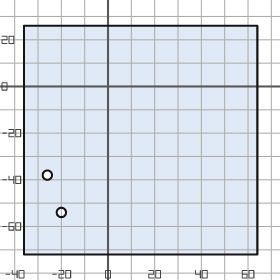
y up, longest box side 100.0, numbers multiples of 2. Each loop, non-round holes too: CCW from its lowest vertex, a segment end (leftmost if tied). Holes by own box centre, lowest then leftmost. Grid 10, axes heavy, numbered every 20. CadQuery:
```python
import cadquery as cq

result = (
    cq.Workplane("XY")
    .moveTo(-36.0, -72.0)
    .lineTo(64.0, -72.0)
    .lineTo(64.0, 26.0)
    .lineTo(-36.0, 26.0)
    .close()
    .moveTo(-20.0, -54.0)
    .circle(2.0)
    .moveTo(-26.0, -38.0)
    .circle(2.0)
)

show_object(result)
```